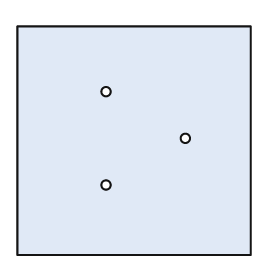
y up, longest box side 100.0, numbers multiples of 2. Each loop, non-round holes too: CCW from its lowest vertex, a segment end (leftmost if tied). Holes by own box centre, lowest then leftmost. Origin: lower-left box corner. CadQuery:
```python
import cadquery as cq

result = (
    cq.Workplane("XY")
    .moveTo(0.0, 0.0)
    .lineTo(100.0, 0.0)
    .lineTo(100.0, 98.0)
    .lineTo(0.0, 98.0)
    .close()
    .moveTo(38.0, 30.0)
    .circle(2.0)
    .moveTo(72.0, 50.0)
    .circle(2.0)
    .moveTo(38.0, 70.0)
    .circle(2.0)
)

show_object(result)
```